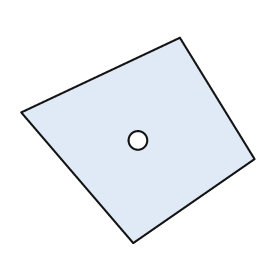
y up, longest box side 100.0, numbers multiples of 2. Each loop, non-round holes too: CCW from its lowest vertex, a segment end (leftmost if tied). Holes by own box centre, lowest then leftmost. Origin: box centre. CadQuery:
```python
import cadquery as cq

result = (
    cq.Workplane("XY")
    .moveTo(-2.0, -44.0)
    .lineTo(50.0, -8.0)
    .lineTo(18.0, 44.0)
    .lineTo(-50.0, 12.0)
    .close()
    .moveTo(0.0, 0.0)
    .circle(4.0)
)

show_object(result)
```